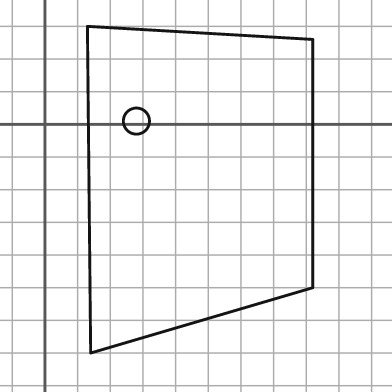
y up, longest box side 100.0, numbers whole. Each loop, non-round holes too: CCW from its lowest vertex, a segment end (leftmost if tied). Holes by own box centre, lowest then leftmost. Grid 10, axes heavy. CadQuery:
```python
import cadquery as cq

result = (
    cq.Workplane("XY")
    .moveTo(14.0, -70.0)
    .lineTo(82.0, -50.0)
    .lineTo(82.0, 26.0)
    .lineTo(13.0, 30.0)
    .close()
    .moveTo(28.0, 1.0)
    .circle(4.0)
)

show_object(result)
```